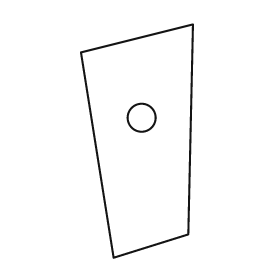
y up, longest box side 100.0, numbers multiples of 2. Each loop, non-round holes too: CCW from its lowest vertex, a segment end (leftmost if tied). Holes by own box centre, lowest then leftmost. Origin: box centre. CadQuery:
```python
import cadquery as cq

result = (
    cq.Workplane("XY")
    .moveTo(-10.0, -50.0)
    .lineTo(22.0, -40.0)
    .lineTo(24.0, 50.0)
    .lineTo(-24.0, 38.0)
    .close()
    .moveTo(2.0, 10.0)
    .circle(6.0)
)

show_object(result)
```